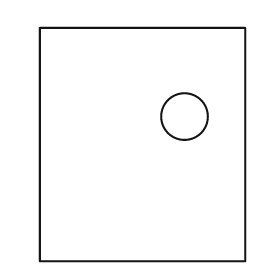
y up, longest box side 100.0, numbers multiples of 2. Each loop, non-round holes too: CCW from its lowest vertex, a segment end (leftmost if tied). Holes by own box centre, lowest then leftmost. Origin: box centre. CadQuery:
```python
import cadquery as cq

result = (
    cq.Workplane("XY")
    .moveTo(-44.0, -50.0)
    .lineTo(44.0, -50.0)
    .lineTo(44.0, 50.0)
    .lineTo(-44.0, 50.0)
    .close()
    .moveTo(18.0, 12.0)
    .circle(10.0)
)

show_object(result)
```